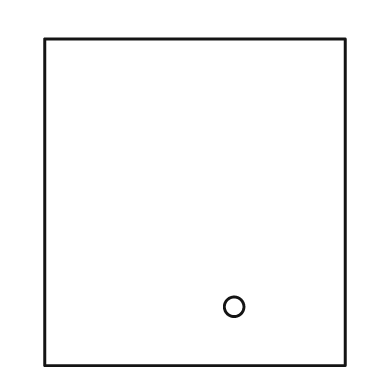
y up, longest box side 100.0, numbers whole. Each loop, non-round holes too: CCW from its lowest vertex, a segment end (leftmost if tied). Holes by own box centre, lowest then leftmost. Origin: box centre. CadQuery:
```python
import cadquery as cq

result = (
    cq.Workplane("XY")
    .moveTo(-46.0, -50.0)
    .lineTo(46.0, -50.0)
    .lineTo(46.0, 50.0)
    .lineTo(-46.0, 50.0)
    .close()
    .moveTo(12.0, -32.0)
    .circle(3.0)
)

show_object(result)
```